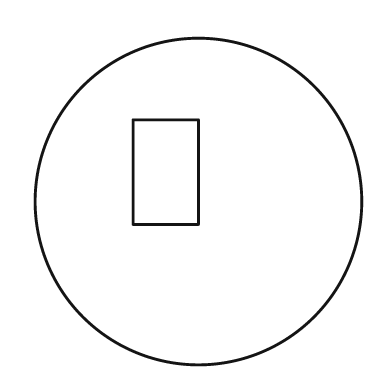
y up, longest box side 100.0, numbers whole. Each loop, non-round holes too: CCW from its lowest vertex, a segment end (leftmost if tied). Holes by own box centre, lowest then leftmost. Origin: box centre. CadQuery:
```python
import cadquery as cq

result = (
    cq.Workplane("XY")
    .moveTo(0.0, 0.0)
    .circle(50.0)
    .moveTo(-20.0, -7.0)
    .lineTo(0.0, -7.0)
    .lineTo(0.0, 25.0)
    .lineTo(-20.0, 25.0)
    .close()
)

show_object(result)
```